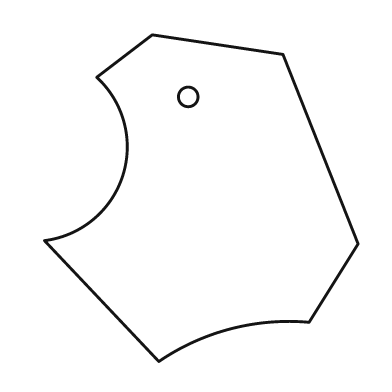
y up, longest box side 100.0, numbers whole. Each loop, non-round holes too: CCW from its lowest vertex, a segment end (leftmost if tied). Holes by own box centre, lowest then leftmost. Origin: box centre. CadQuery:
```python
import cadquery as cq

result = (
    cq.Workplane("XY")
    .moveTo(-13.0, -50.0)
    .threePointArc((9.0, -40.0), (33.0, -38.0))
    .lineTo(48.0, -14.0)
    .lineTo(25.0, 44.0)
    .lineTo(-15.0, 50.0)
    .lineTo(-32.0, 37.0)
    .threePointArc((-24.0, 7.0), (-48.0, -13.0))
    .close()
    .moveTo(-4.0, 31.0)
    .circle(3.0)
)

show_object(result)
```